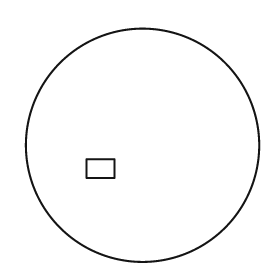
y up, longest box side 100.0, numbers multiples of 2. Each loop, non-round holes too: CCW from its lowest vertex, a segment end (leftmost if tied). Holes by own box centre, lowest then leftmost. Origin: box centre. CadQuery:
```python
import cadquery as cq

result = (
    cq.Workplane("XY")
    .moveTo(0.0, 0.0)
    .circle(50.0)
    .moveTo(-24.0, -14.0)
    .lineTo(-12.0, -14.0)
    .lineTo(-12.0, -6.0)
    .lineTo(-24.0, -6.0)
    .close()
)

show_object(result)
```